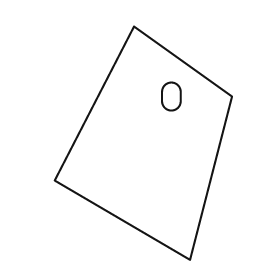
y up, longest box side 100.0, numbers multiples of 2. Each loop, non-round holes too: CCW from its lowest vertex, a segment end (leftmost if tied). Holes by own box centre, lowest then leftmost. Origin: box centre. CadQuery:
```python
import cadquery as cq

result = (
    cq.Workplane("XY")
    .moveTo(20.0, -50.0)
    .lineTo(38.0, 20.0)
    .lineTo(-4.0, 50.0)
    .lineTo(-38.0, -16.0)
    .close()
    .moveTo(8.0, 18.0)
    .threePointArc((12.0, 14.0), (16.0, 18.0))
    .lineTo(16.0, 22.0)
    .threePointArc((12.0, 26.0), (8.0, 22.0))
    .close()
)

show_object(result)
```